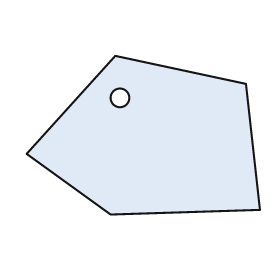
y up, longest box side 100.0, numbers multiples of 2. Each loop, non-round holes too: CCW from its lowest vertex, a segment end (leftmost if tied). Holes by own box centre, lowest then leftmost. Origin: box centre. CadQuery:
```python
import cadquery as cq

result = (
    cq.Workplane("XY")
    .moveTo(-14.0, -34.0)
    .lineTo(50.0, -32.0)
    .lineTo(44.0, 22.0)
    .lineTo(-12.0, 34.0)
    .lineTo(-50.0, -8.0)
    .close()
    .moveTo(-10.0, 16.0)
    .circle(4.0)
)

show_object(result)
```